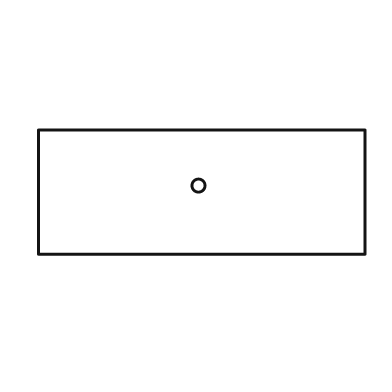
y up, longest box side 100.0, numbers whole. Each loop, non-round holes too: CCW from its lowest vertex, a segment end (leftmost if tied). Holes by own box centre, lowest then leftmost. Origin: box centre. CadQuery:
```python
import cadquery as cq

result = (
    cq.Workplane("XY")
    .moveTo(-50.0, -19.0)
    .lineTo(50.0, -19.0)
    .lineTo(50.0, 19.0)
    .lineTo(-50.0, 19.0)
    .close()
    .moveTo(-1.0, 2.0)
    .circle(2.0)
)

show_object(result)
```